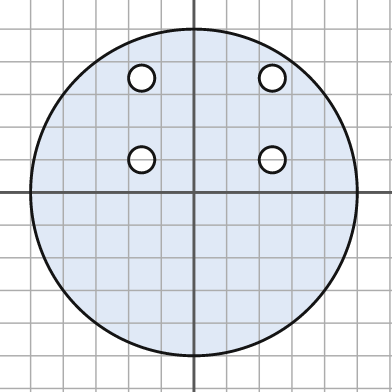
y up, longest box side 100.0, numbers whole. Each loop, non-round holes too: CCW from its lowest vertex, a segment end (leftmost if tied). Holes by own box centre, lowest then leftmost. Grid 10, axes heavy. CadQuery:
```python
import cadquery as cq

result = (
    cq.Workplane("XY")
    .moveTo(0.0, 0.0)
    .circle(50.0)
    .moveTo(-16.0, 10.0)
    .circle(4.0)
    .moveTo(24.0, 10.0)
    .circle(4.0)
    .moveTo(-16.0, 35.0)
    .circle(4.0)
    .moveTo(24.0, 35.0)
    .circle(4.0)
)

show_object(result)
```